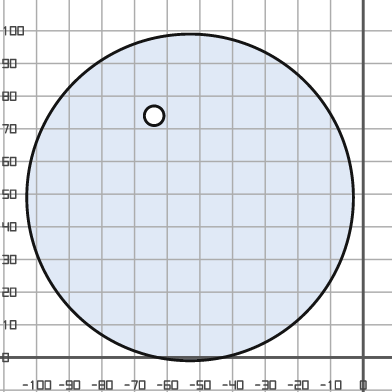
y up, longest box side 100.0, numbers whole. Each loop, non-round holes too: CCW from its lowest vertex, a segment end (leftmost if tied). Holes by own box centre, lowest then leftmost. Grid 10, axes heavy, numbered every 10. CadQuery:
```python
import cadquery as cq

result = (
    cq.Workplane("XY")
    .moveTo(-53.0, 49.0)
    .circle(50.0)
    .moveTo(-64.0, 74.0)
    .circle(3.0)
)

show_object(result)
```